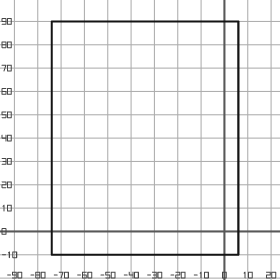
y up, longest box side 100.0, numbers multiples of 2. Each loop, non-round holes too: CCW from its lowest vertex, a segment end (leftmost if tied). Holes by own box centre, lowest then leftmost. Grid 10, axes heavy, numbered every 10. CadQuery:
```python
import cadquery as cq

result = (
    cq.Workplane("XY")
    .moveTo(-74.0, -10.0)
    .lineTo(6.0, -10.0)
    .lineTo(6.0, 90.0)
    .lineTo(-74.0, 90.0)
    .close()
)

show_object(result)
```